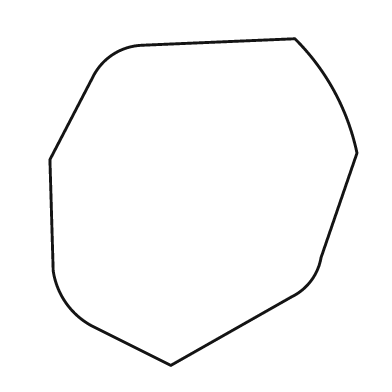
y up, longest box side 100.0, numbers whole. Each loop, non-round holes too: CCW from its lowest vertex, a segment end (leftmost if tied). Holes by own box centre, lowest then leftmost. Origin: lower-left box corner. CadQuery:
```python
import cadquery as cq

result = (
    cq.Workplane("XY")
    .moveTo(37.0, 0.0)
    .lineTo(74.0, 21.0)
    .threePointArc((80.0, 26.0), (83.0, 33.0))
    .lineTo(94.0, 65.0)
    .threePointArc((87.0, 84.0), (75.0, 100.0))
    .lineTo(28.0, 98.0)
    .threePointArc((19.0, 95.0), (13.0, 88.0))
    .lineTo(0.0, 63.0)
    .lineTo(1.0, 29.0)
    .threePointArc((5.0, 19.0), (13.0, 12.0))
    .close()
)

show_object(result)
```